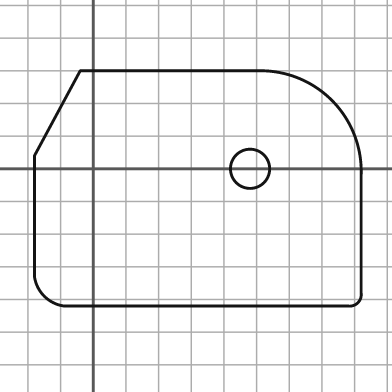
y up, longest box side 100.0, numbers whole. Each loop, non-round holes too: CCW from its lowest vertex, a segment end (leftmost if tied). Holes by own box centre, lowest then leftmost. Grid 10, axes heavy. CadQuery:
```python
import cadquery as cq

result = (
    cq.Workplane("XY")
    .moveTo(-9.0, -42.0)
    .lineTo(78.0, -42.0)
    .threePointArc((81.0, -41.0), (82.0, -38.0))
    .lineTo(82.0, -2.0)
    .threePointArc((73.0, 21.0), (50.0, 30.0))
    .lineTo(-4.0, 30.0)
    .lineTo(-18.0, 4.0)
    .lineTo(-18.0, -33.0)
    .threePointArc((-15.0, -39.0), (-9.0, -42.0))
    .close()
    .moveTo(48.0, 0.0)
    .circle(6.0)
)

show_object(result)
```